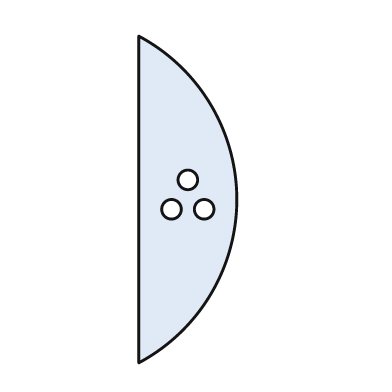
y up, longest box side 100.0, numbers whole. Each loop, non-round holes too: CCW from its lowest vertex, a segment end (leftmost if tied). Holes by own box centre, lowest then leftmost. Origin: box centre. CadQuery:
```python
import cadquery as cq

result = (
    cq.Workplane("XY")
    .moveTo(-15.0, -50.0)
    .threePointArc((15.0, 0.0), (-15.0, 50.0))
    .close()
    .moveTo(-5.0, -3.0)
    .circle(3.0)
    .moveTo(5.0, -3.0)
    .circle(3.0)
    .moveTo(0.0, 6.0)
    .circle(3.0)
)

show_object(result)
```